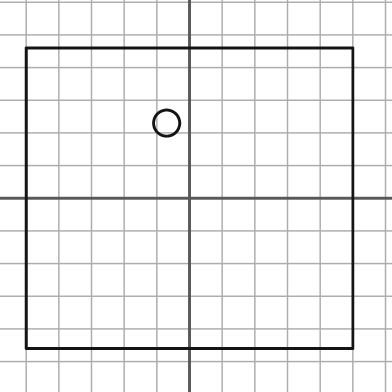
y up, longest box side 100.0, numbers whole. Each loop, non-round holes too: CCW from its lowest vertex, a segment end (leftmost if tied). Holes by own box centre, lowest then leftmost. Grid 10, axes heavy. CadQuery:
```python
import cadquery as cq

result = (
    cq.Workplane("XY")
    .moveTo(-50.0, -46.0)
    .lineTo(50.0, -46.0)
    .lineTo(50.0, 46.0)
    .lineTo(-50.0, 46.0)
    .close()
    .moveTo(-7.0, 23.0)
    .circle(4.0)
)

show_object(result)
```